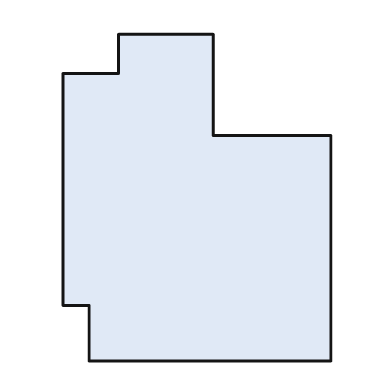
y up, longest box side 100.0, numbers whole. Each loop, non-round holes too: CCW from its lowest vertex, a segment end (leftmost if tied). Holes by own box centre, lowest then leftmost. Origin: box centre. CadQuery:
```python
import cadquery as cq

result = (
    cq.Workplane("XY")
    .moveTo(-33.0, -50.0)
    .lineTo(41.0, -50.0)
    .lineTo(41.0, 19.0)
    .lineTo(5.0, 19.0)
    .lineTo(5.0, 50.0)
    .lineTo(-24.0, 50.0)
    .lineTo(-24.0, 38.0)
    .lineTo(-41.0, 38.0)
    .lineTo(-41.0, -33.0)
    .lineTo(-33.0, -33.0)
    .close()
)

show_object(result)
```